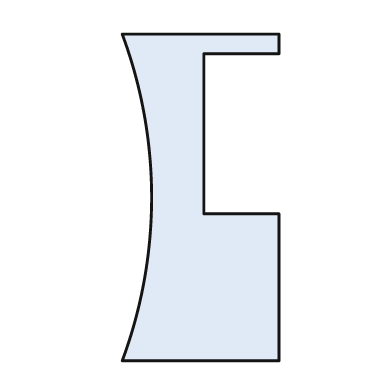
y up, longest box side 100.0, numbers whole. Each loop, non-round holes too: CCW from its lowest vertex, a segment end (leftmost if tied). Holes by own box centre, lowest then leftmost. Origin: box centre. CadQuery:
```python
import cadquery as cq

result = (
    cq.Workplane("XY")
    .moveTo(-24.0, -50.0)
    .lineTo(24.0, -50.0)
    .lineTo(24.0, -5.0)
    .lineTo(1.0, -5.0)
    .lineTo(1.0, 44.0)
    .lineTo(24.0, 44.0)
    .lineTo(24.0, 50.0)
    .lineTo(-24.0, 50.0)
    .threePointArc((-15.0, 0.0), (-24.0, -50.0))
    .close()
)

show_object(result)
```